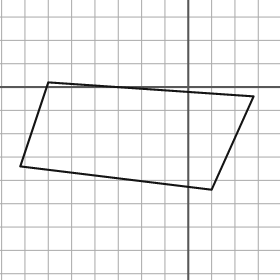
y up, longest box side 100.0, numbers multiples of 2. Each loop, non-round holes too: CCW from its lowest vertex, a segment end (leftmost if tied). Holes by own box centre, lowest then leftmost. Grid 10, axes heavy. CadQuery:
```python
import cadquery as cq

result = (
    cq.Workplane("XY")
    .moveTo(10.0, -44.0)
    .lineTo(28.0, -4.0)
    .lineTo(-60.0, 2.0)
    .lineTo(-72.0, -34.0)
    .close()
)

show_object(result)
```